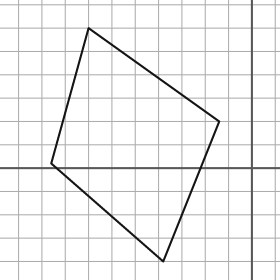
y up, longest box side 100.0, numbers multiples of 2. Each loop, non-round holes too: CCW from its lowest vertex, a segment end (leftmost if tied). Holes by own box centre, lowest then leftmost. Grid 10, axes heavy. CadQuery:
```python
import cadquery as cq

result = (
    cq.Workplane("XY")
    .moveTo(-38.0, -40.0)
    .lineTo(-14.0, 20.0)
    .lineTo(-70.0, 60.0)
    .lineTo(-86.0, 2.0)
    .close()
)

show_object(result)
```